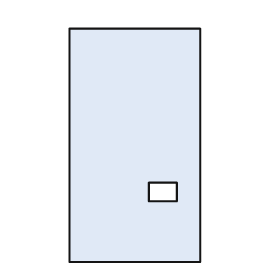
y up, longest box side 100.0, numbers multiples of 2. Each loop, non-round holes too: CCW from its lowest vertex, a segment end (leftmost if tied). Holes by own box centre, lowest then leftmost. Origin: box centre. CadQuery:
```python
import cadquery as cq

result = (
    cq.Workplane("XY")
    .moveTo(-28.0, -50.0)
    .lineTo(28.0, -50.0)
    .lineTo(28.0, 50.0)
    .lineTo(-28.0, 50.0)
    .close()
    .moveTo(6.0, -24.0)
    .lineTo(18.0, -24.0)
    .lineTo(18.0, -16.0)
    .lineTo(6.0, -16.0)
    .close()
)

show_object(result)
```